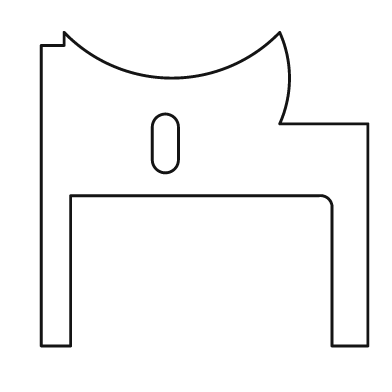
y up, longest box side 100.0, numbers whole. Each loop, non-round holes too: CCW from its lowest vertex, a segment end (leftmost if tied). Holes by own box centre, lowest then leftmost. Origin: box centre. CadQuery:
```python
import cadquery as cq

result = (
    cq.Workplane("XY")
    .moveTo(-50.0, -48.0)
    .lineTo(-41.0, -48.0)
    .lineTo(-41.0, -2.0)
    .lineTo(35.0, -2.0)
    .threePointArc((38.0, -3.0), (39.0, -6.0))
    .lineTo(39.0, -48.0)
    .lineTo(50.0, -48.0)
    .lineTo(50.0, 20.0)
    .lineTo(23.0, 20.0)
    .threePointArc((26.0, 34.0), (23.0, 48.0))
    .threePointArc((-10.0, 34.0), (-43.0, 48.0))
    .lineTo(-43.0, 44.0)
    .lineTo(-50.0, 44.0)
    .close()
    .moveTo(-16.0, 9.0)
    .threePointArc((-12.0, 5.0), (-8.0, 9.0))
    .lineTo(-8.0, 19.0)
    .threePointArc((-12.0, 23.0), (-16.0, 19.0))
    .close()
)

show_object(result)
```